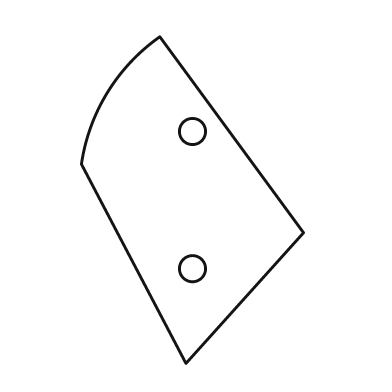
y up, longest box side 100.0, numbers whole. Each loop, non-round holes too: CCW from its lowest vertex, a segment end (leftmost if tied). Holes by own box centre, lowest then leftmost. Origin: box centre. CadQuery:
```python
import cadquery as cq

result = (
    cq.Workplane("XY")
    .moveTo(-2.0, -50.0)
    .lineTo(34.0, -10.0)
    .lineTo(-10.0, 50.0)
    .threePointArc((-26.0, 33.0), (-34.0, 11.0))
    .close()
    .moveTo(0.0, -21.0)
    .circle(4.0)
    .moveTo(0.0, 21.0)
    .circle(4.0)
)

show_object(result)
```